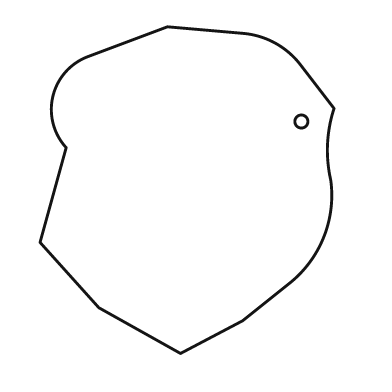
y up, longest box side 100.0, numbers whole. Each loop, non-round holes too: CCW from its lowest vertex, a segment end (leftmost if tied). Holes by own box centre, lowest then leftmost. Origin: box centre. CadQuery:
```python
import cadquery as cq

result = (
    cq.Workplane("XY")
    .moveTo(-2.0, -50.0)
    .lineTo(17.0, -40.0)
    .lineTo(32.0, -28.0)
    .threePointArc((42.0, -14.0), (44.0, 3.0))
    .threePointArc((43.0, 14.0), (45.0, 25.0))
    .lineTo(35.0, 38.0)
    .threePointArc((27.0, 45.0), (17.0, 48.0))
    .lineTo(-6.0, 50.0)
    .lineTo(-30.0, 41.0)
    .threePointArc((-41.0, 29.0), (-37.0, 13.0))
    .lineTo(-45.0, -16.0)
    .lineTo(-27.0, -36.0)
    .close()
    .moveTo(35.0, 21.0)
    .circle(2.0)
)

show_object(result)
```